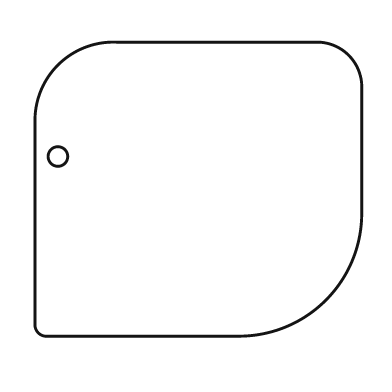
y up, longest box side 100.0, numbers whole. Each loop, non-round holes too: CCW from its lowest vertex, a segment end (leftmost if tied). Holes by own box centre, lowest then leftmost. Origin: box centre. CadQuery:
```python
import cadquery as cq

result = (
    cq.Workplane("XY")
    .moveTo(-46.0, -45.0)
    .lineTo(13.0, -45.0)
    .threePointArc((39.0, -34.0), (50.0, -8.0))
    .lineTo(50.0, 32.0)
    .threePointArc((46.0, 41.0), (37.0, 45.0))
    .lineTo(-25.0, 45.0)
    .threePointArc((-43.0, 38.0), (-50.0, 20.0))
    .lineTo(-50.0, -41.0)
    .threePointArc((-49.0, -44.0), (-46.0, -45.0))
    .close()
    .moveTo(-43.0, 10.0)
    .circle(3.0)
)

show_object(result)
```